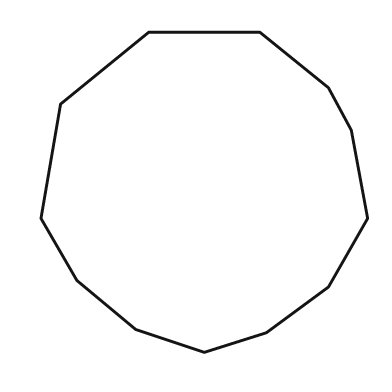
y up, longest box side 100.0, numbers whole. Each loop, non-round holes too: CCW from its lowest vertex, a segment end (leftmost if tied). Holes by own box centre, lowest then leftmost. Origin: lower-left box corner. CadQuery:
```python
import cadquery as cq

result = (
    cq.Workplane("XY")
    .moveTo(50.0, 0.0)
    .lineTo(69.0, 6.0)
    .lineTo(88.0, 20.0)
    .lineTo(100.0, 41.0)
    .lineTo(95.0, 68.0)
    .lineTo(88.0, 81.0)
    .lineTo(67.0, 98.0)
    .lineTo(33.0, 98.0)
    .lineTo(6.0, 76.0)
    .lineTo(0.0, 41.0)
    .lineTo(11.0, 22.0)
    .lineTo(29.0, 7.0)
    .close()
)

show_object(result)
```